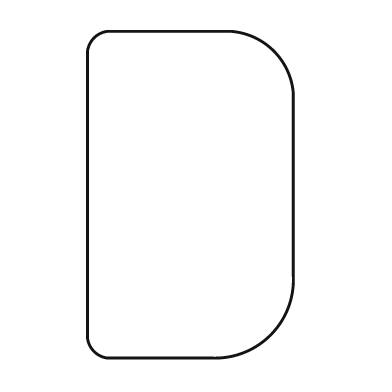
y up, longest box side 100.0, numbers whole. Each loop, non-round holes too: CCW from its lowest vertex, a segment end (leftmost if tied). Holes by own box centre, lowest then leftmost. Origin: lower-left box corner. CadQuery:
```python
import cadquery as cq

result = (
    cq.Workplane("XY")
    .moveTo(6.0, 0.0)
    .lineTo(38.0, 0.0)
    .threePointArc((56.0, 7.0), (63.0, 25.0))
    .lineTo(63.0, 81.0)
    .threePointArc((57.0, 94.0), (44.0, 100.0))
    .lineTo(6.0, 100.0)
    .threePointArc((2.0, 98.0), (0.0, 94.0))
    .lineTo(0.0, 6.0)
    .threePointArc((2.0, 2.0), (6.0, 0.0))
    .close()
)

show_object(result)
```